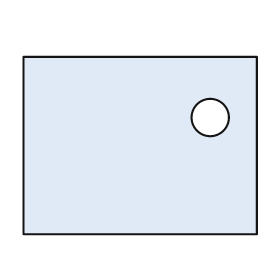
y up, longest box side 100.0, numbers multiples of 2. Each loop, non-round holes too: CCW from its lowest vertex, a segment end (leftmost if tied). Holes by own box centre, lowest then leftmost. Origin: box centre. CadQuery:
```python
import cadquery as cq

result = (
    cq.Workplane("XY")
    .moveTo(-50.0, -38.0)
    .lineTo(50.0, -38.0)
    .lineTo(50.0, 38.0)
    .lineTo(-50.0, 38.0)
    .close()
    .moveTo(30.0, 12.0)
    .circle(8.0)
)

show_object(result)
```